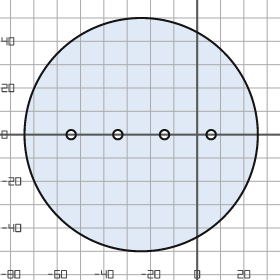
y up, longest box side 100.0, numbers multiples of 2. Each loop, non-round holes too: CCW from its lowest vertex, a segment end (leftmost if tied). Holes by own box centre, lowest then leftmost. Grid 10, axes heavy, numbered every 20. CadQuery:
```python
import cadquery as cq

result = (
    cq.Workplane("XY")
    .moveTo(-24.0, 0.0)
    .circle(50.0)
    .moveTo(-54.0, 0.0)
    .circle(2.0)
    .moveTo(-34.0, 0.0)
    .circle(2.0)
    .moveTo(-14.0, 0.0)
    .circle(2.0)
    .moveTo(6.0, 0.0)
    .circle(2.0)
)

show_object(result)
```